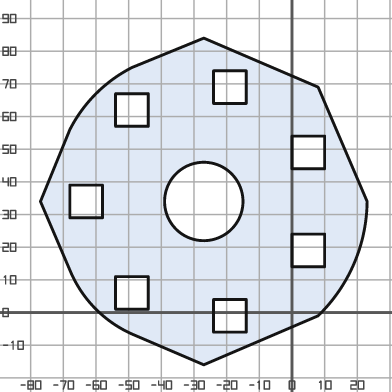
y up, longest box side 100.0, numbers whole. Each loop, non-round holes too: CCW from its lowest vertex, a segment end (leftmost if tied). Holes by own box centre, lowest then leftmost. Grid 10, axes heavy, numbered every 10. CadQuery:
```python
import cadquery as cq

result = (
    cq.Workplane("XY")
    .moveTo(-27.0, -16.0)
    .lineTo(8.0, -1.0)
    .threePointArc((19.0, 15.0), (23.0, 34.0))
    .lineTo(8.0, 69.0)
    .lineTo(-27.0, 84.0)
    .lineTo(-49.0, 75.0)
    .threePointArc((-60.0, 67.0), (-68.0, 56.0))
    .lineTo(-77.0, 34.0)
    .lineTo(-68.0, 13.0)
    .threePointArc((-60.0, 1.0), (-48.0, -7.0))
    .close()
    .moveTo(-24.0, -6.0)
    .lineTo(-14.0, -6.0)
    .lineTo(-14.0, 4.0)
    .lineTo(-24.0, 4.0)
    .close()
    .moveTo(-54.0, 1.0)
    .lineTo(-44.0, 1.0)
    .lineTo(-44.0, 11.0)
    .lineTo(-54.0, 11.0)
    .close()
    .moveTo(0.0, 14.0)
    .lineTo(10.0, 14.0)
    .lineTo(10.0, 24.0)
    .lineTo(0.0, 24.0)
    .close()
    .moveTo(-68.0, 29.0)
    .lineTo(-58.0, 29.0)
    .lineTo(-58.0, 39.0)
    .lineTo(-68.0, 39.0)
    .close()
    .moveTo(-27.0, 34.0)
    .circle(12.0)
    .moveTo(0.0, 44.0)
    .lineTo(10.0, 44.0)
    .lineTo(10.0, 54.0)
    .lineTo(0.0, 54.0)
    .close()
    .moveTo(-54.0, 57.0)
    .lineTo(-44.0, 57.0)
    .lineTo(-44.0, 67.0)
    .lineTo(-54.0, 67.0)
    .close()
    .moveTo(-24.0, 64.0)
    .lineTo(-14.0, 64.0)
    .lineTo(-14.0, 74.0)
    .lineTo(-24.0, 74.0)
    .close()
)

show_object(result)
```